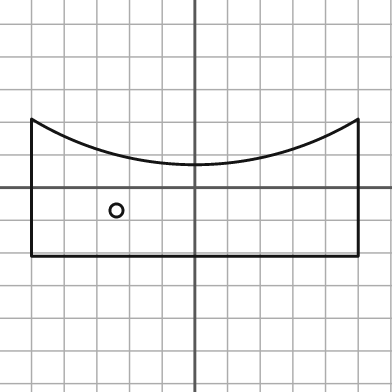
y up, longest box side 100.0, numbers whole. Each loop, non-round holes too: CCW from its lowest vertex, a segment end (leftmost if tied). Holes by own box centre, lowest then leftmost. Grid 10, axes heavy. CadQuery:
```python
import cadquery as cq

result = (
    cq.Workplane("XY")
    .moveTo(-50.0, -21.0)
    .lineTo(50.0, -21.0)
    .lineTo(50.0, 21.0)
    .threePointArc((0.0, 7.0), (-50.0, 21.0))
    .close()
    .moveTo(-24.0, -7.0)
    .circle(2.0)
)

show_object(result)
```